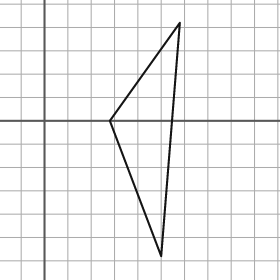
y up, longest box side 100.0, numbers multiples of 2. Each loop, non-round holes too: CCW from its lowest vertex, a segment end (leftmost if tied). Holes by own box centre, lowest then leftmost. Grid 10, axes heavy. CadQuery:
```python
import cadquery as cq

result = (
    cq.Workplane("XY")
    .moveTo(50.0, -58.0)
    .lineTo(58.0, 42.0)
    .lineTo(28.0, 0.0)
    .close()
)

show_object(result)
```